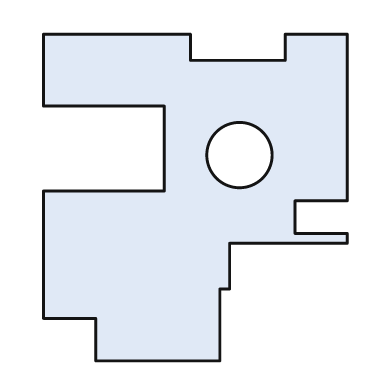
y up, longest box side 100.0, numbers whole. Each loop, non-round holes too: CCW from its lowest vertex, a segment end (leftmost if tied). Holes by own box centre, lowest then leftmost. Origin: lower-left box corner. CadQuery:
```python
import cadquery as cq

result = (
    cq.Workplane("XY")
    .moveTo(16.0, 0.0)
    .lineTo(54.0, 0.0)
    .lineTo(54.0, 22.0)
    .lineTo(57.0, 22.0)
    .lineTo(57.0, 36.0)
    .lineTo(93.0, 36.0)
    .lineTo(93.0, 39.0)
    .lineTo(77.0, 39.0)
    .lineTo(77.0, 49.0)
    .lineTo(93.0, 49.0)
    .lineTo(93.0, 100.0)
    .lineTo(74.0, 100.0)
    .lineTo(74.0, 92.0)
    .lineTo(45.0, 92.0)
    .lineTo(45.0, 100.0)
    .lineTo(0.0, 100.0)
    .lineTo(0.0, 78.0)
    .lineTo(37.0, 78.0)
    .lineTo(37.0, 52.0)
    .lineTo(0.0, 52.0)
    .lineTo(0.0, 13.0)
    .lineTo(16.0, 13.0)
    .close()
    .moveTo(60.0, 63.0)
    .circle(10.0)
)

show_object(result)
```